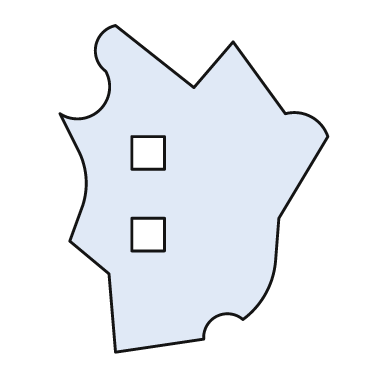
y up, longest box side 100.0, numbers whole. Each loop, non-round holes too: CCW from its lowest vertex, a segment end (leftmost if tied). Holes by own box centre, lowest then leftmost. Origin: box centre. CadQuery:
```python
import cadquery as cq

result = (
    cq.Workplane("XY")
    .moveTo(-24.0, -50.0)
    .lineTo(3.0, -46.0)
    .threePointArc((7.0, -39.0), (15.0, -40.0))
    .threePointArc((22.0, -32.0), (25.0, -22.0))
    .lineTo(26.0, -9.0)
    .lineTo(41.0, 16.0)
    .threePointArc((36.0, 22.0), (28.0, 23.0))
    .lineTo(12.0, 45.0)
    .lineTo(0.0, 31.0)
    .lineTo(-24.0, 50.0)
    .threePointArc((-30.0, 44.0), (-27.0, 36.0))
    .threePointArc((-29.0, 24.0), (-41.0, 23.0))
    .lineTo(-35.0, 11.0)
    .threePointArc((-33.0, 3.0), (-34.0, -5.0))
    .lineTo(-38.0, -16.0)
    .lineTo(-26.0, -26.0)
    .close()
    .moveTo(-19.0, -19.0)
    .lineTo(-9.0, -19.0)
    .lineTo(-9.0, -9.0)
    .lineTo(-19.0, -9.0)
    .close()
    .moveTo(-19.0, 6.0)
    .lineTo(-9.0, 6.0)
    .lineTo(-9.0, 16.0)
    .lineTo(-19.0, 16.0)
    .close()
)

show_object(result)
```